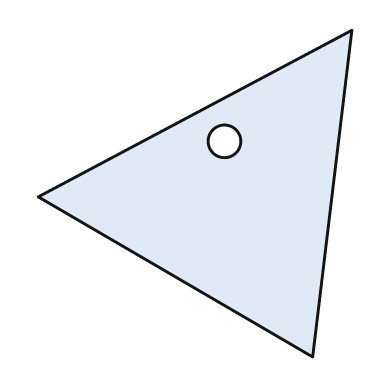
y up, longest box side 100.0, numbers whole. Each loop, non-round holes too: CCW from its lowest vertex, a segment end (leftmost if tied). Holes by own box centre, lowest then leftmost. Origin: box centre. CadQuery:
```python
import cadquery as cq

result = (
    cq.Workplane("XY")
    .moveTo(36.0, -50.0)
    .lineTo(48.0, 50.0)
    .lineTo(-48.0, -1.0)
    .close()
    .moveTo(9.0, 16.0)
    .circle(5.0)
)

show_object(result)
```